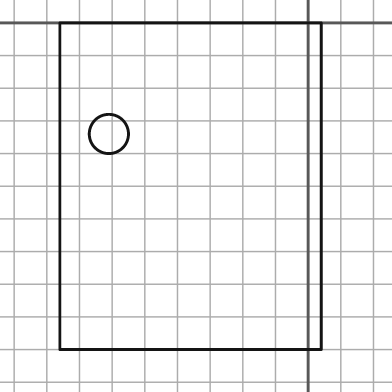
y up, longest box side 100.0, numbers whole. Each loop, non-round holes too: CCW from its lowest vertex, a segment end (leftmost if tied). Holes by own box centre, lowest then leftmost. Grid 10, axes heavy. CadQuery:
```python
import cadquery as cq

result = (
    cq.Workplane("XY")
    .moveTo(-76.0, -100.0)
    .lineTo(4.0, -100.0)
    .lineTo(4.0, 0.0)
    .lineTo(-76.0, 0.0)
    .close()
    .moveTo(-61.0, -34.0)
    .circle(6.0)
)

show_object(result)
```